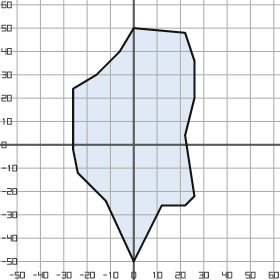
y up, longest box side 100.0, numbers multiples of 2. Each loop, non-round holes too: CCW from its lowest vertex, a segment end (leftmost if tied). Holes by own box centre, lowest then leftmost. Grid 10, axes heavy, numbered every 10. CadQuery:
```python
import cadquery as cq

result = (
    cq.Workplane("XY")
    .moveTo(0.0, -50.0)
    .lineTo(12.0, -26.0)
    .lineTo(22.0, -26.0)
    .lineTo(26.0, -22.0)
    .lineTo(22.0, 4.0)
    .lineTo(26.0, 20.0)
    .lineTo(26.0, 36.0)
    .lineTo(22.0, 48.0)
    .lineTo(0.0, 50.0)
    .lineTo(-6.0, 40.0)
    .lineTo(-16.0, 30.0)
    .lineTo(-26.0, 24.0)
    .lineTo(-26.0, -2.0)
    .lineTo(-24.0, -12.0)
    .lineTo(-12.0, -24.0)
    .close()
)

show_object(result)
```